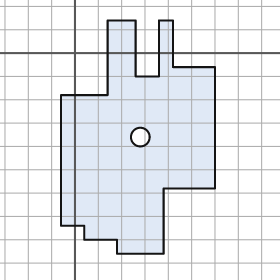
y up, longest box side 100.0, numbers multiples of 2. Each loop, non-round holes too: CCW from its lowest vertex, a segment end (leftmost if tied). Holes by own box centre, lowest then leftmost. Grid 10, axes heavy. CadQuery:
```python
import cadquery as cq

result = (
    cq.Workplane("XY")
    .moveTo(18.0, -86.0)
    .lineTo(38.0, -86.0)
    .lineTo(38.0, -58.0)
    .lineTo(60.0, -58.0)
    .lineTo(60.0, -6.0)
    .lineTo(42.0, -6.0)
    .lineTo(42.0, 14.0)
    .lineTo(36.0, 14.0)
    .lineTo(36.0, -10.0)
    .lineTo(26.0, -10.0)
    .lineTo(26.0, 14.0)
    .lineTo(14.0, 14.0)
    .lineTo(14.0, -18.0)
    .lineTo(-6.0, -18.0)
    .lineTo(-6.0, -74.0)
    .lineTo(4.0, -74.0)
    .lineTo(4.0, -80.0)
    .lineTo(18.0, -80.0)
    .close()
    .moveTo(28.0, -36.0)
    .circle(4.0)
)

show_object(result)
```